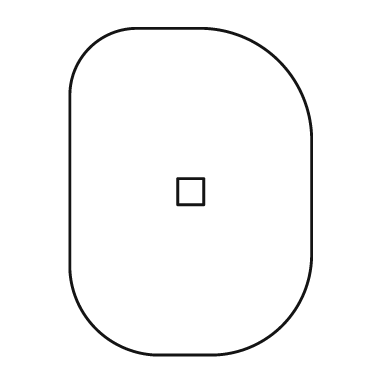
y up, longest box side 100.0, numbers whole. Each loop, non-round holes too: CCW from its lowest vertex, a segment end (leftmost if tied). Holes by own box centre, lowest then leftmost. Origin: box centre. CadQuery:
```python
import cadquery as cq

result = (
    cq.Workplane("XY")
    .moveTo(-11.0, -50.0)
    .lineTo(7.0, -50.0)
    .threePointArc((28.0, -41.0), (37.0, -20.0))
    .lineTo(37.0, 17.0)
    .threePointArc((27.0, 40.0), (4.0, 50.0))
    .lineTo(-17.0, 50.0)
    .threePointArc((-31.0, 44.0), (-37.0, 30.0))
    .lineTo(-37.0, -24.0)
    .threePointArc((-29.0, -42.0), (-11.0, -50.0))
    .close()
    .moveTo(-4.0, -4.0)
    .lineTo(4.0, -4.0)
    .lineTo(4.0, 4.0)
    .lineTo(-4.0, 4.0)
    .close()
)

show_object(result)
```